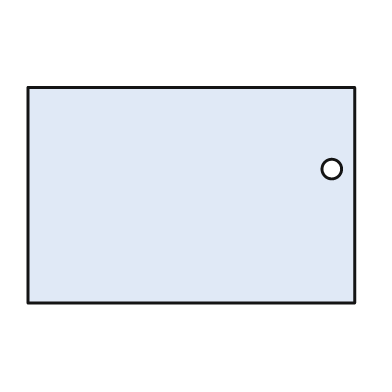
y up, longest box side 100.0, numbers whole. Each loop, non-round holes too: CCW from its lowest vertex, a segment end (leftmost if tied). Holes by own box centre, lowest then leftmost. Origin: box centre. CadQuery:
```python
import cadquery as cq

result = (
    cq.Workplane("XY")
    .moveTo(-50.0, -33.0)
    .lineTo(50.0, -33.0)
    .lineTo(50.0, 33.0)
    .lineTo(-50.0, 33.0)
    .close()
    .moveTo(43.0, 8.0)
    .circle(3.0)
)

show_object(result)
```